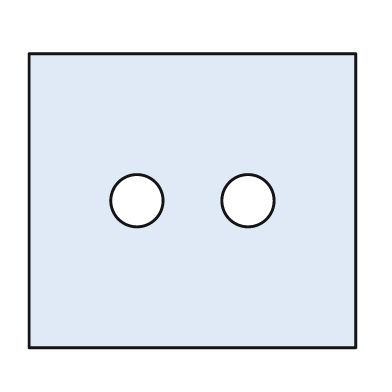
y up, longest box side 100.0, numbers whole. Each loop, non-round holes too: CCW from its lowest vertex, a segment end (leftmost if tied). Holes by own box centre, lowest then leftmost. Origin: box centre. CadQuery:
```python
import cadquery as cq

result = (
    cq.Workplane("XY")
    .moveTo(-50.0, -45.0)
    .lineTo(50.0, -45.0)
    .lineTo(50.0, 45.0)
    .lineTo(-50.0, 45.0)
    .close()
    .moveTo(-17.0, 0.0)
    .circle(8.0)
    .moveTo(17.0, 0.0)
    .circle(8.0)
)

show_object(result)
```